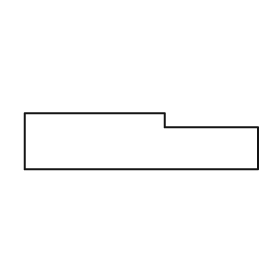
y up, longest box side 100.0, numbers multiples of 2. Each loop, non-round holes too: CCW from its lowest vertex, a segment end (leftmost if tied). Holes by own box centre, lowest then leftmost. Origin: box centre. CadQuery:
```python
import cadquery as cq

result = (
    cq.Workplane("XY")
    .moveTo(-50.0, -12.0)
    .lineTo(50.0, -12.0)
    .lineTo(50.0, 6.0)
    .lineTo(10.0, 6.0)
    .lineTo(10.0, 12.0)
    .lineTo(-50.0, 12.0)
    .close()
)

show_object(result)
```